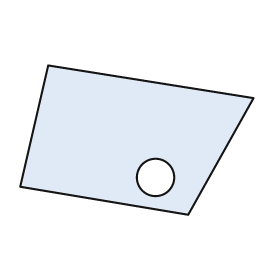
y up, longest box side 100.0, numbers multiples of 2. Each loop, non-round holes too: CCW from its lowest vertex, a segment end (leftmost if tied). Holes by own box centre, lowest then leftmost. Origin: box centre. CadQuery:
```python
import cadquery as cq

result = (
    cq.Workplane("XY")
    .moveTo(22.0, -32.0)
    .lineTo(50.0, 18.0)
    .lineTo(-38.0, 32.0)
    .lineTo(-50.0, -20.0)
    .close()
    .moveTo(8.0, -16.0)
    .circle(8.0)
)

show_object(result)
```